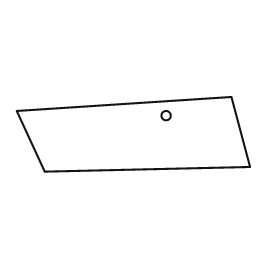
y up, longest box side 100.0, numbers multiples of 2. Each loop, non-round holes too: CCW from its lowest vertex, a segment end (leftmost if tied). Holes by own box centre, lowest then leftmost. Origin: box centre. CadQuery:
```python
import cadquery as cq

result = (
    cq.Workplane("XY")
    .moveTo(-38.0, -16.0)
    .lineTo(50.0, -14.0)
    .lineTo(42.0, 16.0)
    .lineTo(-50.0, 10.0)
    .close()
    .moveTo(14.0, 8.0)
    .circle(2.0)
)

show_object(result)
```